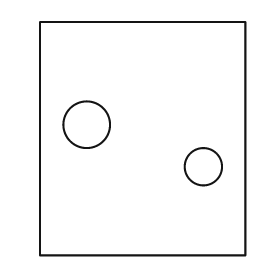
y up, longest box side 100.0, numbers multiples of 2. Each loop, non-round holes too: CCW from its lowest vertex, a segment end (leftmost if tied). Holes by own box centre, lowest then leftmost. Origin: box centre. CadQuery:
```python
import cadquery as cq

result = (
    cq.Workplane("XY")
    .moveTo(-44.0, -50.0)
    .lineTo(44.0, -50.0)
    .lineTo(44.0, 50.0)
    .lineTo(-44.0, 50.0)
    .close()
    .moveTo(26.0, -12.0)
    .circle(8.0)
    .moveTo(-24.0, 6.0)
    .circle(10.0)
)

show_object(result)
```